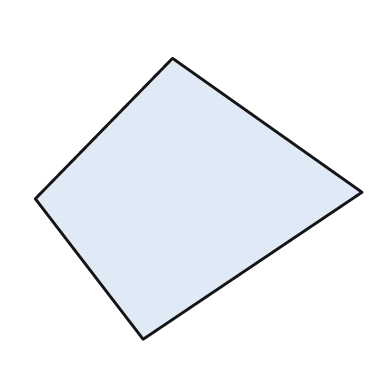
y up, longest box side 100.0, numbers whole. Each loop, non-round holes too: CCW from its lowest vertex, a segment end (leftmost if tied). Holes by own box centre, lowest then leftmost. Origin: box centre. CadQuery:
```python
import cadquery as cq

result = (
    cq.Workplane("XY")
    .moveTo(-17.0, -43.0)
    .lineTo(50.0, 2.0)
    .lineTo(-8.0, 43.0)
    .lineTo(-50.0, 0.0)
    .close()
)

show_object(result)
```